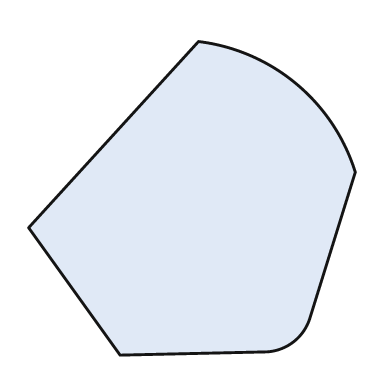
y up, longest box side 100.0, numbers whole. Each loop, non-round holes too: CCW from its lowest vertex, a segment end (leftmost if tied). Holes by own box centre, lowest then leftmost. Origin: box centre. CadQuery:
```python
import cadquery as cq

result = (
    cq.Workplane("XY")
    .moveTo(-22.0, -48.0)
    .lineTo(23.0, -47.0)
    .threePointArc((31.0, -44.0), (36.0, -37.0))
    .lineTo(50.0, 8.0)
    .threePointArc((32.0, 35.0), (2.0, 48.0))
    .lineTo(-50.0, -9.0)
    .close()
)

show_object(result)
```